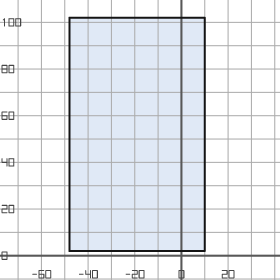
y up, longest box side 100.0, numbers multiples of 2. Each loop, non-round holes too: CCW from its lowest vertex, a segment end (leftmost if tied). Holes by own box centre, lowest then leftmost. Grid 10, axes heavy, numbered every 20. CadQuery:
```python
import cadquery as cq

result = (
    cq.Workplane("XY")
    .moveTo(-48.0, 2.0)
    .lineTo(10.0, 2.0)
    .lineTo(10.0, 102.0)
    .lineTo(-48.0, 102.0)
    .close()
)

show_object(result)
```